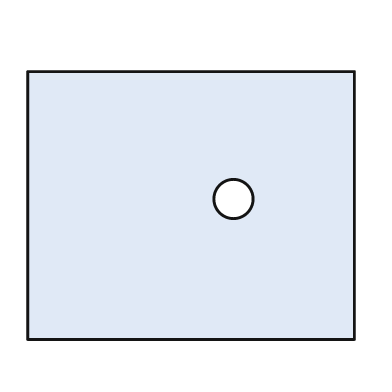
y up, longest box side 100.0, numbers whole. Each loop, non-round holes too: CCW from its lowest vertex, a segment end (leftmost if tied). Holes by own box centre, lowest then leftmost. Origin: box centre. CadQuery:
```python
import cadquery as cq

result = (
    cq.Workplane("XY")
    .moveTo(-50.0, -41.0)
    .lineTo(50.0, -41.0)
    .lineTo(50.0, 41.0)
    .lineTo(-50.0, 41.0)
    .close()
    .moveTo(13.0, 2.0)
    .circle(6.0)
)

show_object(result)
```